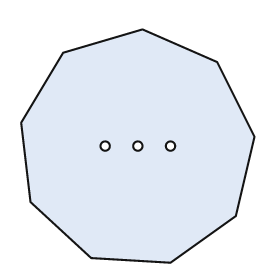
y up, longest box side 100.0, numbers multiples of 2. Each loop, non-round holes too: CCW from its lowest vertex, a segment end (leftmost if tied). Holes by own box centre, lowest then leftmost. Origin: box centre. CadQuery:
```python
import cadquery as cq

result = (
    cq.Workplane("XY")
    .moveTo(14.0, -50.0)
    .lineTo(42.0, -30.0)
    .lineTo(50.0, 4.0)
    .lineTo(34.0, 36.0)
    .lineTo(2.0, 50.0)
    .lineTo(-32.0, 40.0)
    .lineTo(-50.0, 10.0)
    .lineTo(-46.0, -24.0)
    .lineTo(-20.0, -48.0)
    .close()
    .moveTo(-14.0, 0.0)
    .circle(2.0)
    .moveTo(0.0, 0.0)
    .circle(2.0)
    .moveTo(14.0, 0.0)
    .circle(2.0)
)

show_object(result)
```